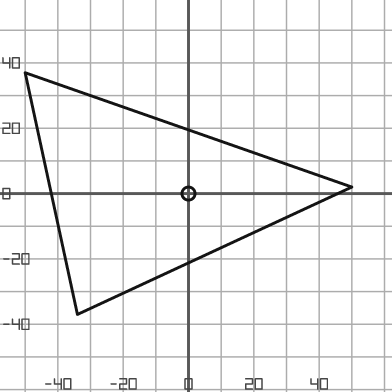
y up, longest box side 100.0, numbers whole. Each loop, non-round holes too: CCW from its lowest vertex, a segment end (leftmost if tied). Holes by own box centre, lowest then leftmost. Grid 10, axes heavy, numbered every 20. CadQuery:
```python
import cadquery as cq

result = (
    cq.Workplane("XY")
    .moveTo(-34.0, -37.0)
    .lineTo(50.0, 2.0)
    .lineTo(-50.0, 37.0)
    .close()
    .moveTo(0.0, 0.0)
    .circle(2.0)
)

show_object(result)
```